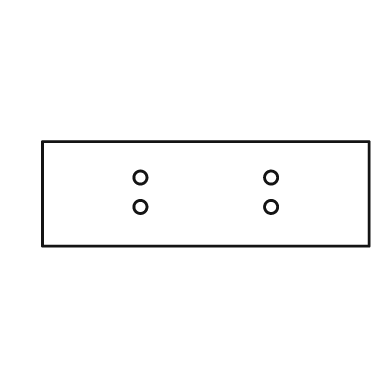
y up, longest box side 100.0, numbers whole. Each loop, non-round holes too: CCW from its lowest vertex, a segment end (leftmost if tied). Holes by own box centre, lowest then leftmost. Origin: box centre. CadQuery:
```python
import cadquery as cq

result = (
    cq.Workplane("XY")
    .moveTo(-50.0, -16.0)
    .lineTo(50.0, -16.0)
    .lineTo(50.0, 16.0)
    .lineTo(-50.0, 16.0)
    .close()
    .moveTo(-20.0, -4.0)
    .circle(2.0)
    .moveTo(20.0, -4.0)
    .circle(2.0)
    .moveTo(-20.0, 5.0)
    .circle(2.0)
    .moveTo(20.0, 5.0)
    .circle(2.0)
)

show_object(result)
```